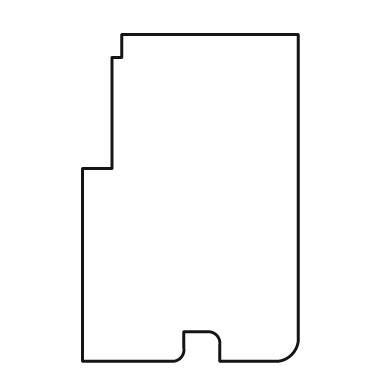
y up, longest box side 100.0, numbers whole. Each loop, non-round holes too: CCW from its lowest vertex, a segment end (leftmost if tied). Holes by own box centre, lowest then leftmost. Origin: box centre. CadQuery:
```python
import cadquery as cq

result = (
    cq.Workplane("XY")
    .moveTo(-33.0, -50.0)
    .lineTo(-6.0, -50.0)
    .threePointArc((-3.0, -49.0), (-2.0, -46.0))
    .lineTo(-2.0, -41.0)
    .lineTo(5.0, -41.0)
    .threePointArc((8.0, -42.0), (9.0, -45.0))
    .lineTo(9.0, -50.0)
    .lineTo(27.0, -50.0)
    .threePointArc((31.0, -48.0), (33.0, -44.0))
    .lineTo(33.0, 50.0)
    .lineTo(-21.0, 50.0)
    .lineTo(-21.0, 43.0)
    .lineTo(-24.0, 43.0)
    .lineTo(-24.0, 9.0)
    .lineTo(-33.0, 9.0)
    .close()
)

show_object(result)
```